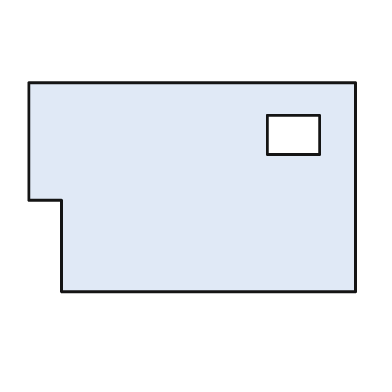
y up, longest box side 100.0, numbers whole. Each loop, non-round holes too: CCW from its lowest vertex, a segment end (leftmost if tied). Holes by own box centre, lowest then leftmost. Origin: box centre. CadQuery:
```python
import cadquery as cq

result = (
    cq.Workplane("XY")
    .moveTo(-40.0, -32.0)
    .lineTo(50.0, -32.0)
    .lineTo(50.0, 32.0)
    .lineTo(-50.0, 32.0)
    .lineTo(-50.0, -4.0)
    .lineTo(-40.0, -4.0)
    .close()
    .moveTo(23.0, 10.0)
    .lineTo(39.0, 10.0)
    .lineTo(39.0, 22.0)
    .lineTo(23.0, 22.0)
    .close()
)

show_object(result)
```